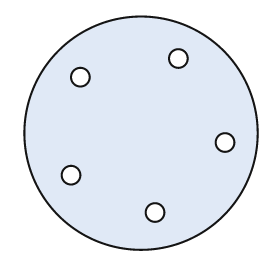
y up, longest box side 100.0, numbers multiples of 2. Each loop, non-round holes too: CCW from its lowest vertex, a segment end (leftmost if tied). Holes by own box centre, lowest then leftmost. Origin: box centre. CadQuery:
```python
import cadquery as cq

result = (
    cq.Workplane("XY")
    .moveTo(0.0, 0.0)
    .circle(50.0)
    .moveTo(6.0, -34.0)
    .circle(4.0)
    .moveTo(-30.0, -18.0)
    .circle(4.0)
    .moveTo(36.0, -4.0)
    .circle(4.0)
    .moveTo(-26.0, 24.0)
    .circle(4.0)
    .moveTo(16.0, 32.0)
    .circle(4.0)
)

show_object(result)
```